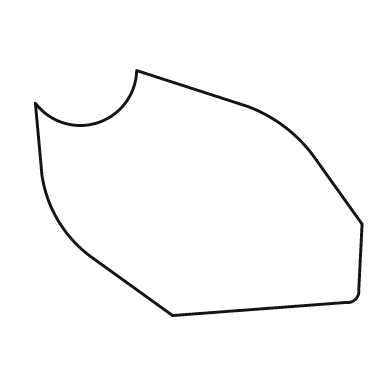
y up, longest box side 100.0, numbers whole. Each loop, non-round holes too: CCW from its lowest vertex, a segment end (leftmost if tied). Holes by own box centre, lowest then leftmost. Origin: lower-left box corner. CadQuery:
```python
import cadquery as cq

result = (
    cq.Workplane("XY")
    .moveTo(42.0, 0.0)
    .lineTo(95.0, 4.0)
    .threePointArc((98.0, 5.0), (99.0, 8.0))
    .lineTo(100.0, 28.0)
    .lineTo(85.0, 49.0)
    .threePointArc((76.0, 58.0), (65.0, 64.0))
    .lineTo(31.0, 75.0)
    .threePointArc((19.0, 59.0), (0.0, 65.0))
    .lineTo(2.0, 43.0)
    .threePointArc((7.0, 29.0), (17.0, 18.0))
    .close()
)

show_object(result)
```